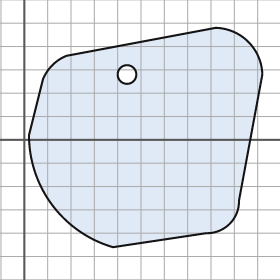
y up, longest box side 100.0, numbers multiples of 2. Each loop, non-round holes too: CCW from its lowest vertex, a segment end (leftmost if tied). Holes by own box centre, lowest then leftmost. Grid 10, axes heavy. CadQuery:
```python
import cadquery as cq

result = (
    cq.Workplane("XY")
    .moveTo(38.0, -46.0)
    .lineTo(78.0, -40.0)
    .threePointArc((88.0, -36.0), (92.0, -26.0))
    .lineTo(102.0, 28.0)
    .threePointArc((96.0, 42.0), (82.0, 48.0))
    .lineTo(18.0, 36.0)
    .threePointArc((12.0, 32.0), (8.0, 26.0))
    .lineTo(2.0, 2.0)
    .threePointArc((12.0, -28.0), (38.0, -46.0))
    .close()
    .moveTo(44.0, 28.0)
    .circle(4.0)
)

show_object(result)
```